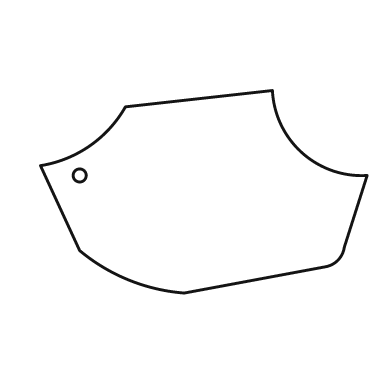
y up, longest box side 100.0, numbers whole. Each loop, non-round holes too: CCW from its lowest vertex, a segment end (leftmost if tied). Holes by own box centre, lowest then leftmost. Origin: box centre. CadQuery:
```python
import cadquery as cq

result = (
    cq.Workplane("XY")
    .moveTo(-6.0, -31.0)
    .lineTo(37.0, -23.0)
    .threePointArc((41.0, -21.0), (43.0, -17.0))
    .lineTo(50.0, 5.0)
    .threePointArc((30.0, 12.0), (21.0, 31.0))
    .lineTo(-24.0, 26.0)
    .threePointArc((-35.0, 14.0), (-50.0, 8.0))
    .lineTo(-38.0, -18.0)
    .threePointArc((-23.0, -27.0), (-6.0, -31.0))
    .close()
    .moveTo(-38.0, 5.0)
    .circle(2.0)
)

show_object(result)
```